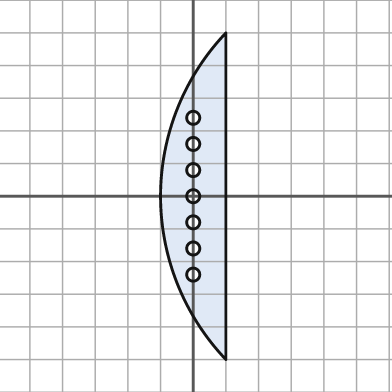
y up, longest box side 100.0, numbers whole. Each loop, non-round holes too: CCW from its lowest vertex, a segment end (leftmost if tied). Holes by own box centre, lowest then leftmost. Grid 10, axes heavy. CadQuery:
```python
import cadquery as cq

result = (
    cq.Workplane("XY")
    .moveTo(10.0, -50.0)
    .lineTo(10.0, 50.0)
    .threePointArc((-10.0, 0.0), (10.0, -50.0))
    .close()
    .moveTo(0.0, -24.0)
    .circle(2.0)
    .moveTo(0.0, -16.0)
    .circle(2.0)
    .moveTo(0.0, -8.0)
    .circle(2.0)
    .moveTo(0.0, 0.0)
    .circle(2.0)
    .moveTo(0.0, 8.0)
    .circle(2.0)
    .moveTo(0.0, 16.0)
    .circle(2.0)
    .moveTo(0.0, 24.0)
    .circle(2.0)
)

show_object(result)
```